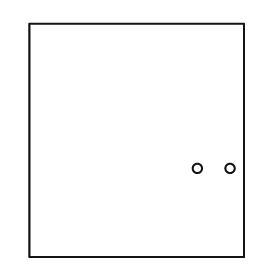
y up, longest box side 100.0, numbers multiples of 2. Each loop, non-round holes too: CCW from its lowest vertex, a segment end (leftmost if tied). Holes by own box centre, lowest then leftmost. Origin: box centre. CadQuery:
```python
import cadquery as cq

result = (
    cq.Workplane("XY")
    .moveTo(-46.0, -50.0)
    .lineTo(46.0, -50.0)
    .lineTo(46.0, 50.0)
    .lineTo(-46.0, 50.0)
    .close()
    .moveTo(26.0, -12.0)
    .circle(2.0)
    .moveTo(40.0, -12.0)
    .circle(2.0)
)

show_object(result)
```